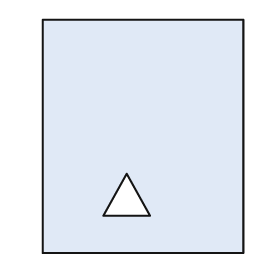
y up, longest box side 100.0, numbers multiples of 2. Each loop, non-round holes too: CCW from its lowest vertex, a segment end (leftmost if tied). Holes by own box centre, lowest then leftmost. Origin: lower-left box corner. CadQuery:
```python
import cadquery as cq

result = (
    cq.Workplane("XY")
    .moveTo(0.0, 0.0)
    .lineTo(86.0, 0.0)
    .lineTo(86.0, 100.0)
    .lineTo(0.0, 100.0)
    .close()
    .moveTo(26.0, 16.0)
    .lineTo(46.0, 16.0)
    .lineTo(36.0, 34.0)
    .close()
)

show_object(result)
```